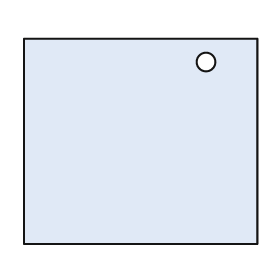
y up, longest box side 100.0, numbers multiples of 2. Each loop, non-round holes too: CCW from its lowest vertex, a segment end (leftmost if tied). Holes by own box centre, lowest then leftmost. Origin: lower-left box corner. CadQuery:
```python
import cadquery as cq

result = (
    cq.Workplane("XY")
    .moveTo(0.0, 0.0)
    .lineTo(100.0, 0.0)
    .lineTo(100.0, 88.0)
    .lineTo(0.0, 88.0)
    .close()
    .moveTo(78.0, 78.0)
    .circle(4.0)
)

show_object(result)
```